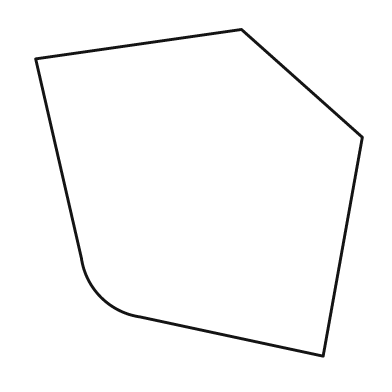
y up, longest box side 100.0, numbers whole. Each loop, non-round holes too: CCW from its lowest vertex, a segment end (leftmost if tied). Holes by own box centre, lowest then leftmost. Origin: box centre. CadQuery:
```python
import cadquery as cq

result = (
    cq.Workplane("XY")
    .moveTo(38.0, -50.0)
    .lineTo(50.0, 17.0)
    .lineTo(13.0, 50.0)
    .lineTo(-50.0, 41.0)
    .lineTo(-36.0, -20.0)
    .threePointArc((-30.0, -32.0), (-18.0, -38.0))
    .close()
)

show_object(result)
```